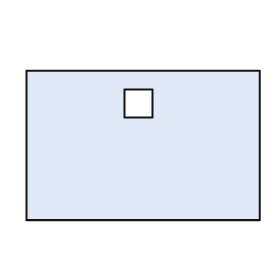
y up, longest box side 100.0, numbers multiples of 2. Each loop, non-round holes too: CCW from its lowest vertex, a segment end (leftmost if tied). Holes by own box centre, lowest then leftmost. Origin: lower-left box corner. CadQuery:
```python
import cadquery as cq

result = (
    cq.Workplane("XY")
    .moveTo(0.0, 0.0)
    .lineTo(100.0, 0.0)
    .lineTo(100.0, 64.0)
    .lineTo(0.0, 64.0)
    .close()
    .moveTo(42.0, 44.0)
    .lineTo(54.0, 44.0)
    .lineTo(54.0, 56.0)
    .lineTo(42.0, 56.0)
    .close()
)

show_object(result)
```